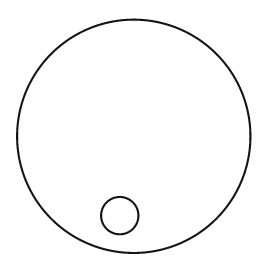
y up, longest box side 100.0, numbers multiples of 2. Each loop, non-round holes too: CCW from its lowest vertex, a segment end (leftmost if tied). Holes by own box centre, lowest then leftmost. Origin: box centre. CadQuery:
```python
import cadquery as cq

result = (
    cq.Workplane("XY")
    .moveTo(0.0, 0.0)
    .circle(50.0)
    .moveTo(-6.0, -34.0)
    .circle(8.0)
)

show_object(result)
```